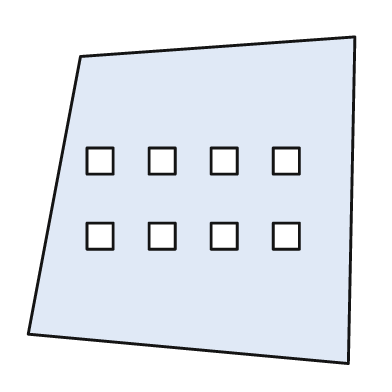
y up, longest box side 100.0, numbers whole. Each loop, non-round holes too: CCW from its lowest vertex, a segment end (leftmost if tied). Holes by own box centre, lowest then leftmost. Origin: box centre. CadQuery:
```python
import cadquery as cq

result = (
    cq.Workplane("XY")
    .moveTo(48.0, -50.0)
    .lineTo(50.0, 50.0)
    .lineTo(-34.0, 44.0)
    .lineTo(-50.0, -41.0)
    .close()
    .moveTo(-32.0, -15.0)
    .lineTo(-24.0, -15.0)
    .lineTo(-24.0, -7.0)
    .lineTo(-32.0, -7.0)
    .close()
    .moveTo(-13.0, -15.0)
    .lineTo(-5.0, -15.0)
    .lineTo(-5.0, -7.0)
    .lineTo(-13.0, -7.0)
    .close()
    .moveTo(6.0, -15.0)
    .lineTo(14.0, -15.0)
    .lineTo(14.0, -7.0)
    .lineTo(6.0, -7.0)
    .close()
    .moveTo(25.0, -15.0)
    .lineTo(33.0, -15.0)
    .lineTo(33.0, -7.0)
    .lineTo(25.0, -7.0)
    .close()
    .moveTo(-32.0, 8.0)
    .lineTo(-24.0, 8.0)
    .lineTo(-24.0, 16.0)
    .lineTo(-32.0, 16.0)
    .close()
    .moveTo(-13.0, 8.0)
    .lineTo(-5.0, 8.0)
    .lineTo(-5.0, 16.0)
    .lineTo(-13.0, 16.0)
    .close()
    .moveTo(6.0, 8.0)
    .lineTo(14.0, 8.0)
    .lineTo(14.0, 16.0)
    .lineTo(6.0, 16.0)
    .close()
    .moveTo(25.0, 8.0)
    .lineTo(33.0, 8.0)
    .lineTo(33.0, 16.0)
    .lineTo(25.0, 16.0)
    .close()
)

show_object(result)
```